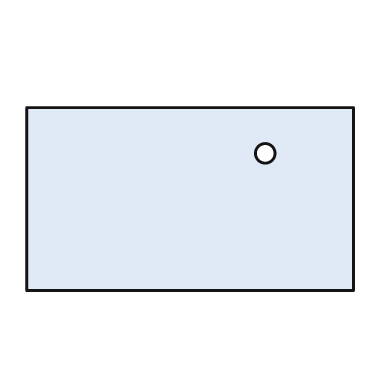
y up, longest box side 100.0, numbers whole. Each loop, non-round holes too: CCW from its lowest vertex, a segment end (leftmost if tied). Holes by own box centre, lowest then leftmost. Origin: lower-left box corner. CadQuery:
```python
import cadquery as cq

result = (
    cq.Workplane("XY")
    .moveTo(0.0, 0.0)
    .lineTo(100.0, 0.0)
    .lineTo(100.0, 56.0)
    .lineTo(0.0, 56.0)
    .close()
    .moveTo(73.0, 42.0)
    .circle(3.0)
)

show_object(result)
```